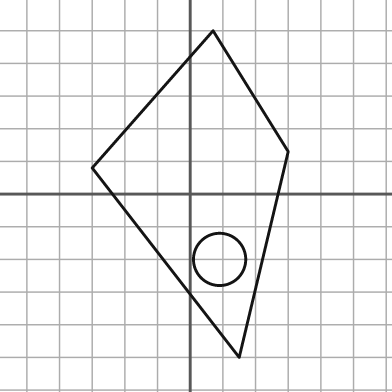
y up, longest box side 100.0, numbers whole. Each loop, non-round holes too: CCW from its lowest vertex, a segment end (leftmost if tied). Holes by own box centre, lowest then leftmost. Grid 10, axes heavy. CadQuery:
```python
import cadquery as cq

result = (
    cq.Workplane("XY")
    .moveTo(15.0, -50.0)
    .lineTo(30.0, 13.0)
    .lineTo(7.0, 50.0)
    .lineTo(-30.0, 8.0)
    .close()
    .moveTo(9.0, -20.0)
    .circle(8.0)
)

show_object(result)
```